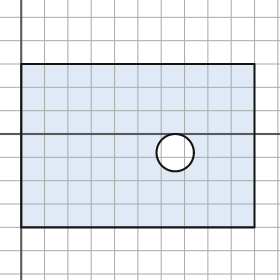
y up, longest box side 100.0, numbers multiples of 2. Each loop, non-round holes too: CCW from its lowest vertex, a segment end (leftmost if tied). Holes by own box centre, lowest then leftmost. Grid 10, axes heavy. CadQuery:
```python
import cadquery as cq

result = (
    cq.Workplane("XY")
    .moveTo(0.0, -40.0)
    .lineTo(100.0, -40.0)
    .lineTo(100.0, 30.0)
    .lineTo(0.0, 30.0)
    .close()
    .moveTo(66.0, -8.0)
    .circle(8.0)
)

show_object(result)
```